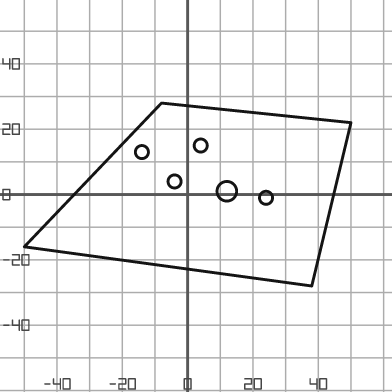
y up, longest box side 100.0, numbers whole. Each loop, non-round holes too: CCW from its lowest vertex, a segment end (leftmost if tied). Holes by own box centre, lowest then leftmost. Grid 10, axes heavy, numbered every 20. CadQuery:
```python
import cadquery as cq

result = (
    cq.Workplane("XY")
    .moveTo(38.0, -28.0)
    .lineTo(50.0, 22.0)
    .lineTo(-8.0, 28.0)
    .lineTo(-50.0, -16.0)
    .close()
    .moveTo(24.0, -1.0)
    .circle(2.0)
    .moveTo(12.0, 1.0)
    .circle(3.0)
    .moveTo(-4.0, 4.0)
    .circle(2.0)
    .moveTo(-14.0, 13.0)
    .circle(2.0)
    .moveTo(4.0, 15.0)
    .circle(2.0)
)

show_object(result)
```